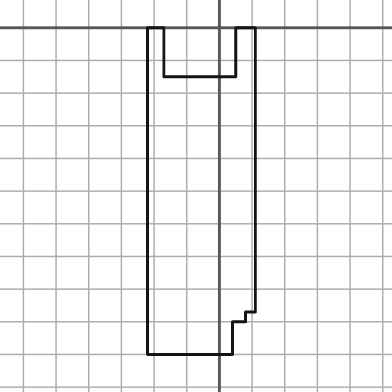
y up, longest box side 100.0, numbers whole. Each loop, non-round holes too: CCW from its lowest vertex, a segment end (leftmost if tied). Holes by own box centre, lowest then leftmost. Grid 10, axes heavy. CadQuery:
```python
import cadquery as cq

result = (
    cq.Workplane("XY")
    .moveTo(-22.0, -100.0)
    .lineTo(4.0, -100.0)
    .lineTo(4.0, -90.0)
    .lineTo(8.0, -90.0)
    .lineTo(8.0, -87.0)
    .lineTo(11.0, -87.0)
    .lineTo(11.0, 0.0)
    .lineTo(5.0, 0.0)
    .lineTo(5.0, -15.0)
    .lineTo(-17.0, -15.0)
    .lineTo(-17.0, 0.0)
    .lineTo(-22.0, 0.0)
    .close()
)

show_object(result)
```